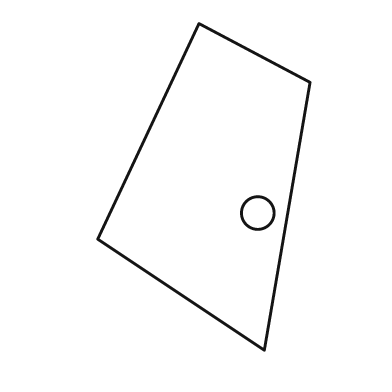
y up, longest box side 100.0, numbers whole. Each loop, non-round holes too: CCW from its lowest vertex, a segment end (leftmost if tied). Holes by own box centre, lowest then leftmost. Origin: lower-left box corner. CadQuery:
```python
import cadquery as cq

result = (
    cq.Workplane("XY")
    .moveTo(51.0, 0.0)
    .lineTo(65.0, 82.0)
    .lineTo(31.0, 100.0)
    .lineTo(0.0, 34.0)
    .close()
    .moveTo(49.0, 42.0)
    .circle(5.0)
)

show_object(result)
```